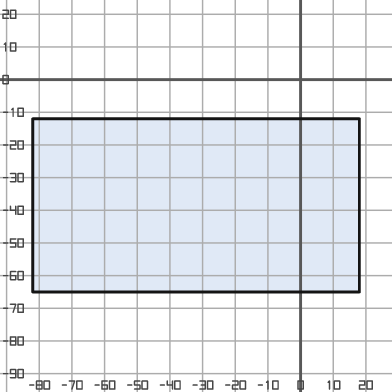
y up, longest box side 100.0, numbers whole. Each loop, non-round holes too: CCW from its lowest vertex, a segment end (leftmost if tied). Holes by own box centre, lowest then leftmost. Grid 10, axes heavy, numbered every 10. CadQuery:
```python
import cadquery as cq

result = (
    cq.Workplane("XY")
    .moveTo(-82.0, -65.0)
    .lineTo(18.0, -65.0)
    .lineTo(18.0, -12.0)
    .lineTo(-82.0, -12.0)
    .close()
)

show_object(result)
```